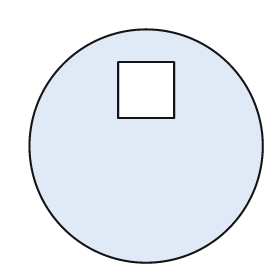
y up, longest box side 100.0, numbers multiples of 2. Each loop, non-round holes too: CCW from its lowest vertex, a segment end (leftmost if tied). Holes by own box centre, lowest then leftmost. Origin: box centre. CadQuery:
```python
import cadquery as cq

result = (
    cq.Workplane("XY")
    .moveTo(0.0, 0.0)
    .circle(50.0)
    .moveTo(-12.0, 12.0)
    .lineTo(12.0, 12.0)
    .lineTo(12.0, 36.0)
    .lineTo(-12.0, 36.0)
    .close()
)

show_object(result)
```